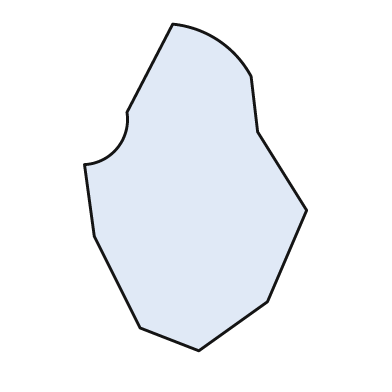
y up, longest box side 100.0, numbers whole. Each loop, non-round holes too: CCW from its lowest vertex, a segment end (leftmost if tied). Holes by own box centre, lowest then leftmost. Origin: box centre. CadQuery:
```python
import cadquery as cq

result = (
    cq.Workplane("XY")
    .moveTo(1.0, -50.0)
    .lineTo(22.0, -35.0)
    .lineTo(34.0, -7.0)
    .lineTo(19.0, 17.0)
    .lineTo(17.0, 34.0)
    .threePointArc((7.0, 45.0), (-7.0, 50.0))
    .lineTo(-21.0, 23.0)
    .threePointArc((-24.0, 12.0), (-34.0, 7.0))
    .lineTo(-31.0, -15.0)
    .lineTo(-17.0, -43.0)
    .close()
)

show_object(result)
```